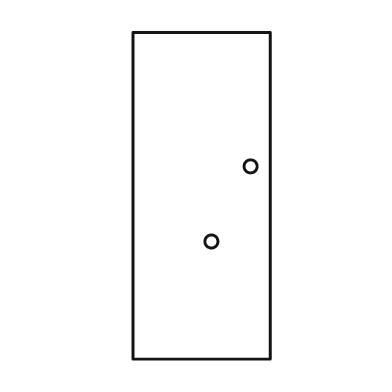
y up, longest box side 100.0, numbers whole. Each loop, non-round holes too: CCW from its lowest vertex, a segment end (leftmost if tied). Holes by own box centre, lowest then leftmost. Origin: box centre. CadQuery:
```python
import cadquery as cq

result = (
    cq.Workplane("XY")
    .moveTo(-21.0, -50.0)
    .lineTo(21.0, -50.0)
    .lineTo(21.0, 50.0)
    .lineTo(-21.0, 50.0)
    .close()
    .moveTo(3.0, -14.0)
    .circle(2.0)
    .moveTo(15.0, 9.0)
    .circle(2.0)
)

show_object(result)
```